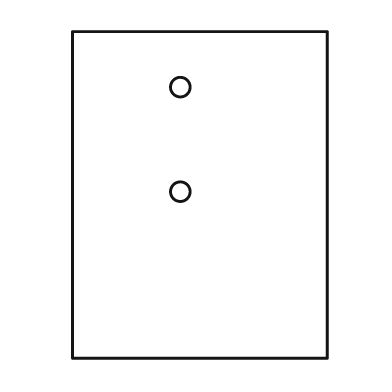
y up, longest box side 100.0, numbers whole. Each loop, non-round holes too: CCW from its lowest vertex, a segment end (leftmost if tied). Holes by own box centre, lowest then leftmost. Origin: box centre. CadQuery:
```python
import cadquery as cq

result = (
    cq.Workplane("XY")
    .moveTo(-39.0, -50.0)
    .lineTo(39.0, -50.0)
    .lineTo(39.0, 50.0)
    .lineTo(-39.0, 50.0)
    .close()
    .moveTo(-6.0, 1.0)
    .circle(3.0)
    .moveTo(-6.0, 33.0)
    .circle(3.0)
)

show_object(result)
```